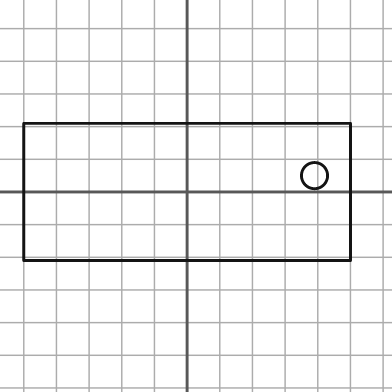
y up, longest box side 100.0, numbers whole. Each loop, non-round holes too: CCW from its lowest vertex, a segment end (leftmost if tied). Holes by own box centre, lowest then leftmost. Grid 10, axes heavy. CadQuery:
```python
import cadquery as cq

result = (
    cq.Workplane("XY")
    .moveTo(-50.0, -21.0)
    .lineTo(50.0, -21.0)
    .lineTo(50.0, 21.0)
    .lineTo(-50.0, 21.0)
    .close()
    .moveTo(39.0, 5.0)
    .circle(4.0)
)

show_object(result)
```